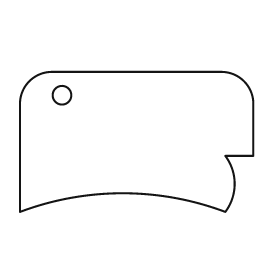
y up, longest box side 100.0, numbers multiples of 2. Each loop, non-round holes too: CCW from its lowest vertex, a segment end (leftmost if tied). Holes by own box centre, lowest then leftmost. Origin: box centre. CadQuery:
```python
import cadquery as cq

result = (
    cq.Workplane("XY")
    .moveTo(-50.0, -30.0)
    .threePointArc((-6.0, -22.0), (38.0, -30.0))
    .threePointArc((42.0, -18.0), (38.0, -6.0))
    .lineTo(50.0, -6.0)
    .lineTo(50.0, 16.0)
    .threePointArc((46.0, 26.0), (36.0, 30.0))
    .lineTo(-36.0, 30.0)
    .threePointArc((-46.0, 26.0), (-50.0, 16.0))
    .close()
    .moveTo(-32.0, 20.0)
    .circle(4.0)
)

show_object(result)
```